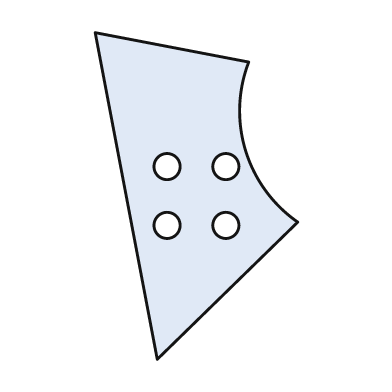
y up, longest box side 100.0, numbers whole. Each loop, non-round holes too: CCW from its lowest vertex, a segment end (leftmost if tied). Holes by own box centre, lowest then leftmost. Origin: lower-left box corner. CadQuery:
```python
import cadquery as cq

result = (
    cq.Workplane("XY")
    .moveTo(19.0, 0.0)
    .lineTo(62.0, 42.0)
    .threePointArc((46.0, 64.0), (47.0, 91.0))
    .lineTo(0.0, 100.0)
    .close()
    .moveTo(22.0, 41.0)
    .circle(4.0)
    .moveTo(40.0, 41.0)
    .circle(4.0)
    .moveTo(22.0, 59.0)
    .circle(4.0)
    .moveTo(40.0, 59.0)
    .circle(4.0)
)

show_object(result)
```